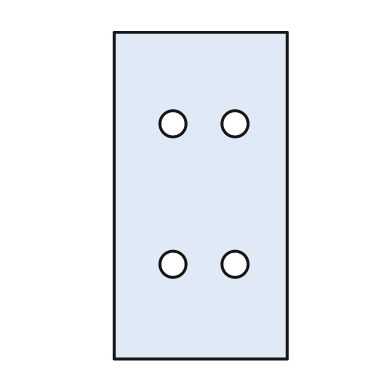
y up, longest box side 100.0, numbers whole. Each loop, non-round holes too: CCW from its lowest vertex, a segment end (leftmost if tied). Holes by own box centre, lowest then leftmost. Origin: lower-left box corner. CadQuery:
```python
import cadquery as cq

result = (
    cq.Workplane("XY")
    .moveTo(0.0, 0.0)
    .lineTo(53.0, 0.0)
    .lineTo(53.0, 100.0)
    .lineTo(0.0, 100.0)
    .close()
    .moveTo(18.0, 29.0)
    .circle(4.0)
    .moveTo(37.0, 29.0)
    .circle(4.0)
    .moveTo(18.0, 72.0)
    .circle(4.0)
    .moveTo(37.0, 72.0)
    .circle(4.0)
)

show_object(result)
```